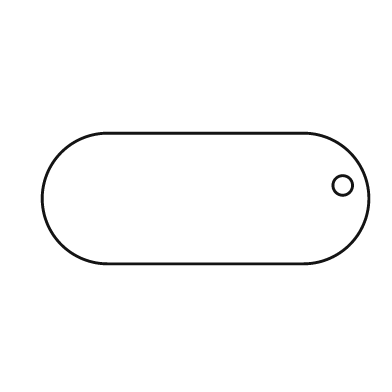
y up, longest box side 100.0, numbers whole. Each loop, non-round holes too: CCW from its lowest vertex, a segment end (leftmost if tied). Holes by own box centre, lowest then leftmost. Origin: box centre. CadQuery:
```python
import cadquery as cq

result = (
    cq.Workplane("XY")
    .moveTo(-30.0, -20.0)
    .lineTo(30.0, -20.0)
    .threePointArc((50.0, 0.0), (30.0, 20.0))
    .lineTo(-30.0, 20.0)
    .threePointArc((-50.0, 0.0), (-30.0, -20.0))
    .close()
    .moveTo(42.0, 4.0)
    .circle(3.0)
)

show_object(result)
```